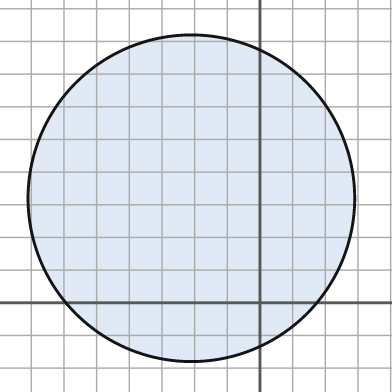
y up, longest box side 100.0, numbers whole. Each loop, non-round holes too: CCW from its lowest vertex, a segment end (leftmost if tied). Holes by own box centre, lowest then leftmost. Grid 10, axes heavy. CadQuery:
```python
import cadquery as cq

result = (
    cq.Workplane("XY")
    .moveTo(-21.0, 32.0)
    .circle(50.0)
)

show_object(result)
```